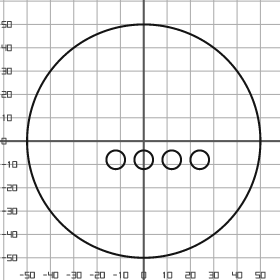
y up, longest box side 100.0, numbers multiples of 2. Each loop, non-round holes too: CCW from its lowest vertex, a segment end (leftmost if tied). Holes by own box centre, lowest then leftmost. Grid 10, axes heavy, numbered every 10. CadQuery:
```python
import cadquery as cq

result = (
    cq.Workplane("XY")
    .moveTo(0.0, 0.0)
    .circle(50.0)
    .moveTo(-12.0, -8.0)
    .circle(4.0)
    .moveTo(0.0, -8.0)
    .circle(4.0)
    .moveTo(12.0, -8.0)
    .circle(4.0)
    .moveTo(24.0, -8.0)
    .circle(4.0)
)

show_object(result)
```